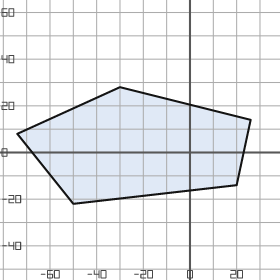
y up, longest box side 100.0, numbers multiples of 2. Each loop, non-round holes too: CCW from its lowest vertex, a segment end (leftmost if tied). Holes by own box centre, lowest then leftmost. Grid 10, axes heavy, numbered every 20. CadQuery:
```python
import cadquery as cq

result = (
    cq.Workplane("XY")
    .moveTo(-50.0, -22.0)
    .lineTo(20.0, -14.0)
    .lineTo(26.0, 14.0)
    .lineTo(-30.0, 28.0)
    .lineTo(-74.0, 8.0)
    .close()
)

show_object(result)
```